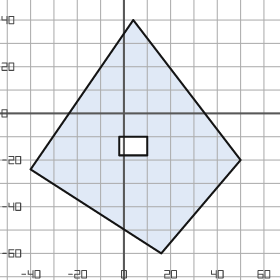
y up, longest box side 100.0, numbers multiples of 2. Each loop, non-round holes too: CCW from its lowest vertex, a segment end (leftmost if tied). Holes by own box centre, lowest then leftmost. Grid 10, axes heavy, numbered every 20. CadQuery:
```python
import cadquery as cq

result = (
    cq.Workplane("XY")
    .moveTo(16.0, -60.0)
    .lineTo(50.0, -20.0)
    .lineTo(4.0, 40.0)
    .lineTo(-40.0, -24.0)
    .close()
    .moveTo(-2.0, -18.0)
    .lineTo(10.0, -18.0)
    .lineTo(10.0, -10.0)
    .lineTo(-2.0, -10.0)
    .close()
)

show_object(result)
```